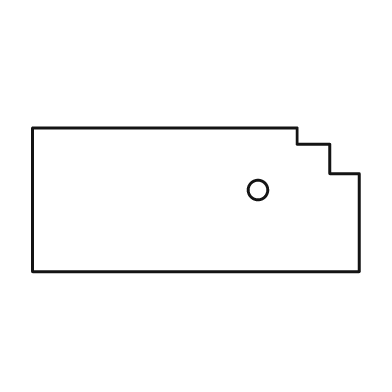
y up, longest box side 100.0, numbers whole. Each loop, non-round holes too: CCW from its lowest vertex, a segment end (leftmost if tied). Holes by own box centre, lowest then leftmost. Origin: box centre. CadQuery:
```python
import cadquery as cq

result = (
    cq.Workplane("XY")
    .moveTo(-50.0, -22.0)
    .lineTo(50.0, -22.0)
    .lineTo(50.0, 8.0)
    .lineTo(41.0, 8.0)
    .lineTo(41.0, 17.0)
    .lineTo(31.0, 17.0)
    .lineTo(31.0, 22.0)
    .lineTo(-50.0, 22.0)
    .close()
    .moveTo(19.0, 3.0)
    .circle(3.0)
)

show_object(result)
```